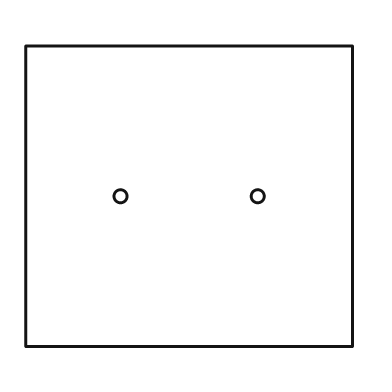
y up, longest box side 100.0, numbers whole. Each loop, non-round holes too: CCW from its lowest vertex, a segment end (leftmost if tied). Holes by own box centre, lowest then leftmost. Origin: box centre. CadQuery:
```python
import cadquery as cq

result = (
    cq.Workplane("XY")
    .moveTo(-50.0, -46.0)
    .lineTo(50.0, -46.0)
    .lineTo(50.0, 46.0)
    .lineTo(-50.0, 46.0)
    .close()
    .moveTo(-21.0, 0.0)
    .circle(2.0)
    .moveTo(21.0, 0.0)
    .circle(2.0)
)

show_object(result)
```